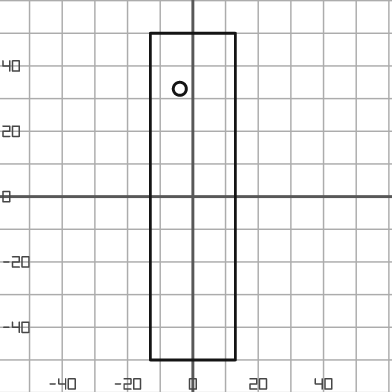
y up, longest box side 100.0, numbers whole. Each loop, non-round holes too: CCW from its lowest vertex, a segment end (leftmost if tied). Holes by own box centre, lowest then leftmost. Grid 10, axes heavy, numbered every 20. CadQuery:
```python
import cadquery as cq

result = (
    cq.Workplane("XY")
    .moveTo(-13.0, -50.0)
    .lineTo(13.0, -50.0)
    .lineTo(13.0, 50.0)
    .lineTo(-13.0, 50.0)
    .close()
    .moveTo(-4.0, 33.0)
    .circle(2.0)
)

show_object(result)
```